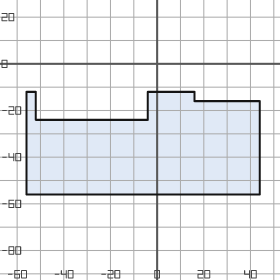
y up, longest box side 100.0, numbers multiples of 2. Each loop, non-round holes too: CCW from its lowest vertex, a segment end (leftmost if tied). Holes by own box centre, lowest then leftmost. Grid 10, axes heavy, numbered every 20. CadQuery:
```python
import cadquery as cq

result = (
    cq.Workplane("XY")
    .moveTo(-56.0, -56.0)
    .lineTo(44.0, -56.0)
    .lineTo(44.0, -16.0)
    .lineTo(16.0, -16.0)
    .lineTo(16.0, -12.0)
    .lineTo(-4.0, -12.0)
    .lineTo(-4.0, -24.0)
    .lineTo(-52.0, -24.0)
    .lineTo(-52.0, -12.0)
    .lineTo(-56.0, -12.0)
    .close()
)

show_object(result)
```